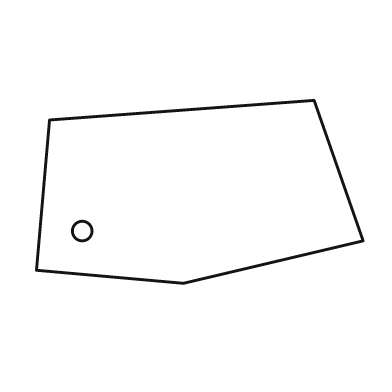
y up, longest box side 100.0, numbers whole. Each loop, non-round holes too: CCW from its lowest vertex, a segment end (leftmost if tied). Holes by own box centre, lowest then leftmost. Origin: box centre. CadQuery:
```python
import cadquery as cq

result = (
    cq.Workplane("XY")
    .moveTo(-5.0, -28.0)
    .lineTo(50.0, -15.0)
    .lineTo(35.0, 28.0)
    .lineTo(-46.0, 22.0)
    .lineTo(-50.0, -24.0)
    .close()
    .moveTo(-36.0, -12.0)
    .circle(3.0)
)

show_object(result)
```